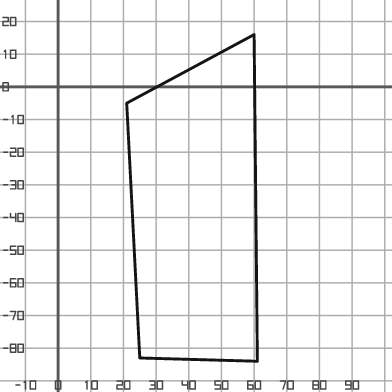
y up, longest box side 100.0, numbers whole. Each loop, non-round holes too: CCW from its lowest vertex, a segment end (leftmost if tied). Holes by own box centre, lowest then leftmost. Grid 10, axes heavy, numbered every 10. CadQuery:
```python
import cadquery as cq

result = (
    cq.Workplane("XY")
    .moveTo(61.0, -84.0)
    .lineTo(60.0, 16.0)
    .lineTo(21.0, -5.0)
    .lineTo(25.0, -83.0)
    .close()
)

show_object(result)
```